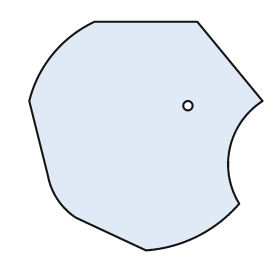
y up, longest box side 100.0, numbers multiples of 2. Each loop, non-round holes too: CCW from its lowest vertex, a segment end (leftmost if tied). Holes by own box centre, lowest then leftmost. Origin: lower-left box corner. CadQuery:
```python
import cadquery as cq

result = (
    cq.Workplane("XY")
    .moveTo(50.0, 0.0)
    .threePointArc((72.0, 6.0), (90.0, 20.0))
    .threePointArc((86.0, 44.0), (100.0, 64.0))
    .lineTo(72.0, 98.0)
    .lineTo(28.0, 98.0)
    .threePointArc((10.0, 84.0), (0.0, 64.0))
    .lineTo(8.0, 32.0)
    .threePointArc((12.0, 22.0), (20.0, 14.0))
    .close()
    .moveTo(68.0, 62.0)
    .circle(2.0)
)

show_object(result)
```